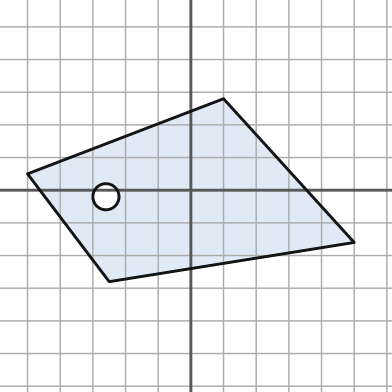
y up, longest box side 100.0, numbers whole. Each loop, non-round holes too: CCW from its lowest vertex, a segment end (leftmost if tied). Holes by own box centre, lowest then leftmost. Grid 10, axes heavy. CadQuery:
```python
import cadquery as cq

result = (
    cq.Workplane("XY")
    .moveTo(-25.0, -28.0)
    .lineTo(50.0, -16.0)
    .lineTo(10.0, 28.0)
    .lineTo(-50.0, 5.0)
    .close()
    .moveTo(-26.0, -2.0)
    .circle(4.0)
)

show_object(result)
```